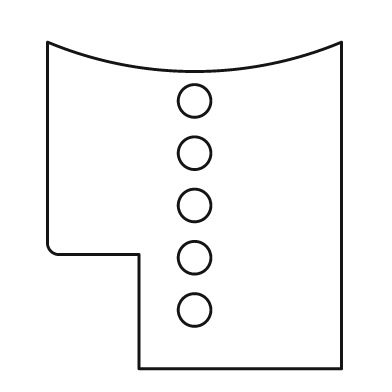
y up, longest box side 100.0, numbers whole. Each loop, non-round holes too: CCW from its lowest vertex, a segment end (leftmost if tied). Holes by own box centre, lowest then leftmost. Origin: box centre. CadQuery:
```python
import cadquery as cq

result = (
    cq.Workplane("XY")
    .moveTo(-17.0, -50.0)
    .lineTo(45.0, -50.0)
    .lineTo(45.0, 50.0)
    .threePointArc((0.0, 41.0), (-45.0, 50.0))
    .lineTo(-45.0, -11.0)
    .threePointArc((-44.0, -14.0), (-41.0, -15.0))
    .lineTo(-17.0, -15.0)
    .close()
    .moveTo(0.0, -32.0)
    .circle(5.0)
    .moveTo(0.0, -16.0)
    .circle(5.0)
    .moveTo(0.0, 0.0)
    .circle(5.0)
    .moveTo(0.0, 16.0)
    .circle(5.0)
    .moveTo(0.0, 32.0)
    .circle(5.0)
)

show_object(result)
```